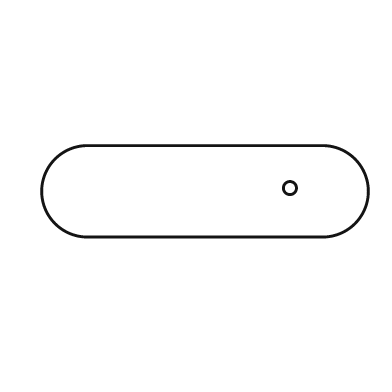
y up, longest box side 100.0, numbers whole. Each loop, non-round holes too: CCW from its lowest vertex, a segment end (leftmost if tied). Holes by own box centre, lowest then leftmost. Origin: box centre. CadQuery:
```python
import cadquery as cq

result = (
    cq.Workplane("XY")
    .moveTo(-36.0, -14.0)
    .lineTo(36.0, -14.0)
    .threePointArc((50.0, 0.0), (36.0, 14.0))
    .lineTo(-36.0, 14.0)
    .threePointArc((-50.0, 0.0), (-36.0, -14.0))
    .close()
    .moveTo(26.0, 1.0)
    .circle(2.0)
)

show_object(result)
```